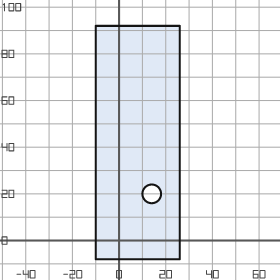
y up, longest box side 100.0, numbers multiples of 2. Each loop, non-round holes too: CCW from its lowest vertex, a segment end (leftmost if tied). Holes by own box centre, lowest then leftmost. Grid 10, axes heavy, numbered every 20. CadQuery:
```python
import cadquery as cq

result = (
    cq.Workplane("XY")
    .moveTo(-10.0, -8.0)
    .lineTo(26.0, -8.0)
    .lineTo(26.0, 92.0)
    .lineTo(-10.0, 92.0)
    .close()
    .moveTo(14.0, 20.0)
    .circle(4.0)
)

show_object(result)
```